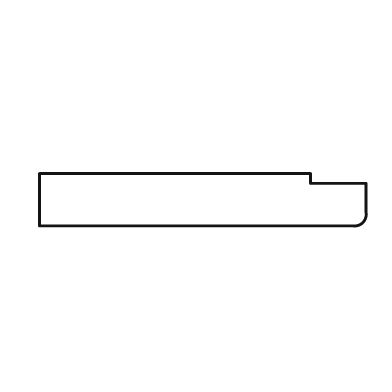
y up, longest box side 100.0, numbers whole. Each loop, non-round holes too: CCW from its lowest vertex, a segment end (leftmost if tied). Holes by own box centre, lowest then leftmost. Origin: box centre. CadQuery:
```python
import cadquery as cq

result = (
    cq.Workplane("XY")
    .moveTo(-50.0, -8.0)
    .lineTo(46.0, -8.0)
    .threePointArc((49.0, -7.0), (50.0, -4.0))
    .lineTo(50.0, 5.0)
    .lineTo(33.0, 5.0)
    .lineTo(33.0, 8.0)
    .lineTo(-50.0, 8.0)
    .close()
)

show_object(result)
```